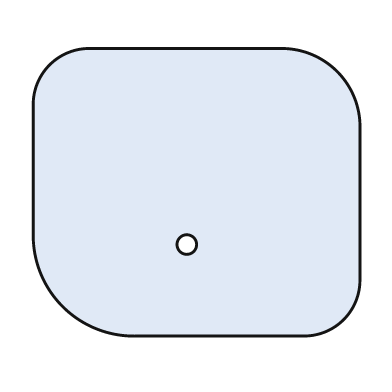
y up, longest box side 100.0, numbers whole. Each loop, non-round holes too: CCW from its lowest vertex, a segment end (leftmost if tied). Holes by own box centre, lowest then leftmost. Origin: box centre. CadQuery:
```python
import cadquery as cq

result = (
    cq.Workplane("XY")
    .moveTo(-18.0, -44.0)
    .lineTo(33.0, -44.0)
    .threePointArc((45.0, -39.0), (50.0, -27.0))
    .lineTo(50.0, 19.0)
    .threePointArc((43.0, 37.0), (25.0, 44.0))
    .lineTo(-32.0, 44.0)
    .threePointArc((-45.0, 39.0), (-50.0, 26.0))
    .lineTo(-50.0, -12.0)
    .threePointArc((-41.0, -35.0), (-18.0, -44.0))
    .close()
    .moveTo(-3.0, -16.0)
    .circle(3.0)
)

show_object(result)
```